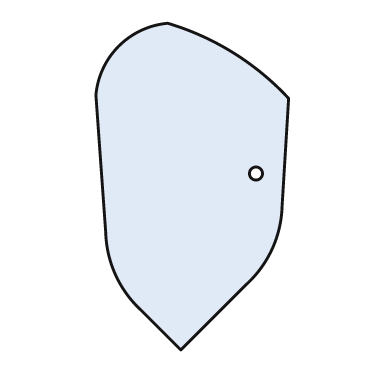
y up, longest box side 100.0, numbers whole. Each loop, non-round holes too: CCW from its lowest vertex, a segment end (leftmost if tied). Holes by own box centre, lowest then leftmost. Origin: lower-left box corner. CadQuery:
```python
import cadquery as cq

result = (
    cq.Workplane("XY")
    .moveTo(26.0, 0.0)
    .lineTo(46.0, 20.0)
    .threePointArc((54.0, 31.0), (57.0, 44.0))
    .lineTo(59.0, 77.0)
    .threePointArc((42.0, 91.0), (22.0, 100.0))
    .threePointArc((7.0, 93.0), (0.0, 78.0))
    .lineTo(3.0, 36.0)
    .threePointArc((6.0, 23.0), (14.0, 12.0))
    .close()
    .moveTo(49.0, 54.0)
    .circle(2.0)
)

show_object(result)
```